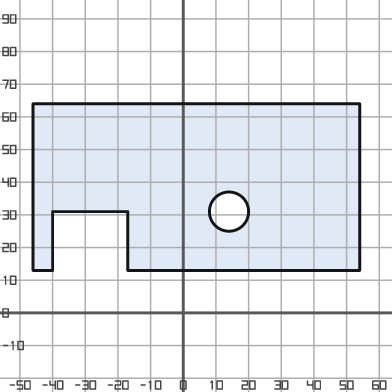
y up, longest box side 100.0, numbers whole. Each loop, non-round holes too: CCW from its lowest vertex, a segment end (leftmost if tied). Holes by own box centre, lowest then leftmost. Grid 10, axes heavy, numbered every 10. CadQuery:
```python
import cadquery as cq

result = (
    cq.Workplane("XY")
    .moveTo(-46.0, 13.0)
    .lineTo(-40.0, 13.0)
    .lineTo(-40.0, 31.0)
    .lineTo(-17.0, 31.0)
    .lineTo(-17.0, 13.0)
    .lineTo(54.0, 13.0)
    .lineTo(54.0, 64.0)
    .lineTo(-46.0, 64.0)
    .close()
    .moveTo(14.0, 31.0)
    .circle(6.0)
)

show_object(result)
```